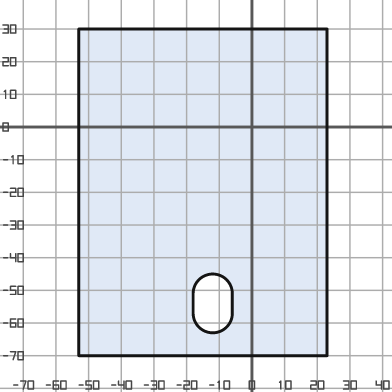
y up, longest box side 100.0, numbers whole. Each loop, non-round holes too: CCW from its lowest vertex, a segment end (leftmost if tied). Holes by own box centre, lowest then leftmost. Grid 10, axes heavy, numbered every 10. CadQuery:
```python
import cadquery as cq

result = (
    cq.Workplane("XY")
    .moveTo(-53.0, -70.0)
    .lineTo(23.0, -70.0)
    .lineTo(23.0, 30.0)
    .lineTo(-53.0, 30.0)
    .close()
    .moveTo(-18.0, -57.0)
    .threePointArc((-12.0, -63.0), (-6.0, -57.0))
    .lineTo(-6.0, -51.0)
    .threePointArc((-12.0, -45.0), (-18.0, -51.0))
    .close()
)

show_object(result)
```